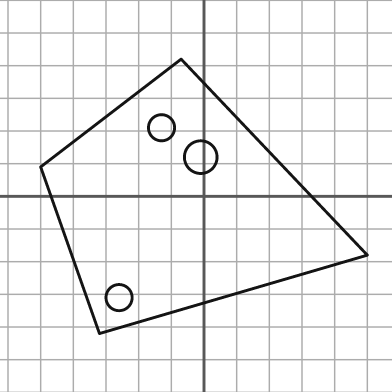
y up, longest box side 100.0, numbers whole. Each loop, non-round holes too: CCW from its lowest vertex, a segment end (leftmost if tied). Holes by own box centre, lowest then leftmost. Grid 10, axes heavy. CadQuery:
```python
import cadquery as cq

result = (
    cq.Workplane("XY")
    .moveTo(-32.0, -42.0)
    .lineTo(50.0, -18.0)
    .lineTo(-7.0, 42.0)
    .lineTo(-50.0, 9.0)
    .close()
    .moveTo(-26.0, -31.0)
    .circle(4.0)
    .moveTo(-1.0, 12.0)
    .circle(5.0)
    .moveTo(-13.0, 21.0)
    .circle(4.0)
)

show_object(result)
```